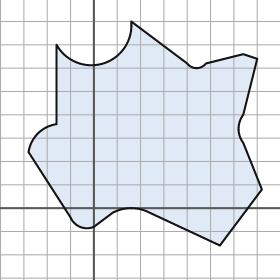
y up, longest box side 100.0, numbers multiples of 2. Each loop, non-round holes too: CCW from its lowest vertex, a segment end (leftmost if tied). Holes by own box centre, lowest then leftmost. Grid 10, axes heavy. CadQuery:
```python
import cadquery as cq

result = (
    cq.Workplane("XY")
    .moveTo(54.0, -16.0)
    .lineTo(72.0, 8.0)
    .lineTo(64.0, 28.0)
    .threePointArc((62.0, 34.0), (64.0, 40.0))
    .lineTo(70.0, 64.0)
    .lineTo(64.0, 66.0)
    .lineTo(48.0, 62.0)
    .threePointArc((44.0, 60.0), (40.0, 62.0))
    .lineTo(16.0, 80.0)
    .threePointArc((4.0, 62.0), (-16.0, 70.0))
    .lineTo(-16.0, 36.0)
    .threePointArc((-24.0, 32.0), (-28.0, 24.0))
    .lineTo(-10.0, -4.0)
    .threePointArc((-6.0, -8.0), (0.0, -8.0))
    .lineTo(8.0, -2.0)
    .threePointArc((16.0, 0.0), (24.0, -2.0))
    .close()
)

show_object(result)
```